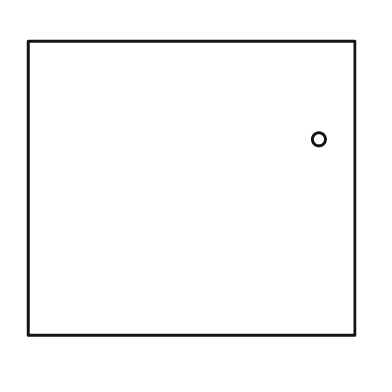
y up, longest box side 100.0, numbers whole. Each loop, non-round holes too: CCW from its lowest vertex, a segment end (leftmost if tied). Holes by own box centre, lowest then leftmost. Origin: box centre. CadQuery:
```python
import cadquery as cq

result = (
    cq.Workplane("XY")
    .moveTo(-50.0, -45.0)
    .lineTo(50.0, -45.0)
    .lineTo(50.0, 45.0)
    .lineTo(-50.0, 45.0)
    .close()
    .moveTo(39.0, 15.0)
    .circle(2.0)
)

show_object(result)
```